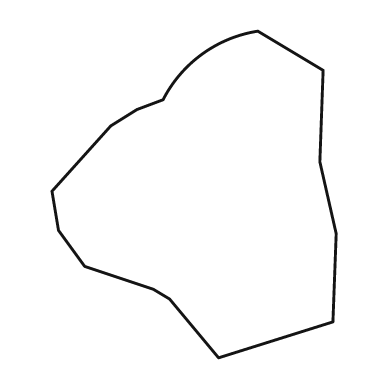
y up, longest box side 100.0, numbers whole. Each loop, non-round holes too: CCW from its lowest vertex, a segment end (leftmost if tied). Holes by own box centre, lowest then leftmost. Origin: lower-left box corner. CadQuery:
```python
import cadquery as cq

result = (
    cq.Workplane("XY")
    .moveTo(51.0, 0.0)
    .lineTo(86.0, 11.0)
    .lineTo(87.0, 38.0)
    .lineTo(82.0, 60.0)
    .lineTo(83.0, 88.0)
    .lineTo(63.0, 100.0)
    .threePointArc((46.0, 93.0), (34.0, 79.0))
    .lineTo(26.0, 76.0)
    .lineTo(18.0, 71.0)
    .lineTo(0.0, 51.0)
    .lineTo(2.0, 39.0)
    .lineTo(10.0, 28.0)
    .lineTo(31.0, 21.0)
    .lineTo(36.0, 18.0)
    .close()
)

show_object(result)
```